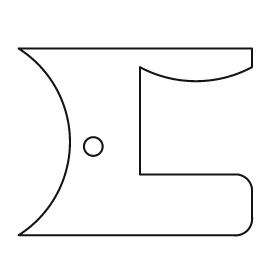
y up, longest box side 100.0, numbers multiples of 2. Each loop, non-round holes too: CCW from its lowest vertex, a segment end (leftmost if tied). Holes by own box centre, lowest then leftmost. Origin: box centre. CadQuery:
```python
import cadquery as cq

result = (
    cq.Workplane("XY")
    .moveTo(-50.0, -40.0)
    .lineTo(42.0, -40.0)
    .threePointArc((48.0, -38.0), (50.0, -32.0))
    .lineTo(50.0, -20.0)
    .threePointArc((48.0, -16.0), (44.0, -14.0))
    .lineTo(2.0, -14.0)
    .lineTo(2.0, 32.0)
    .threePointArc((26.0, 26.0), (50.0, 32.0))
    .lineTo(50.0, 40.0)
    .lineTo(-50.0, 40.0)
    .threePointArc((-28.0, 0.0), (-50.0, -40.0))
    .close()
    .moveTo(-18.0, -2.0)
    .circle(4.0)
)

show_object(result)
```